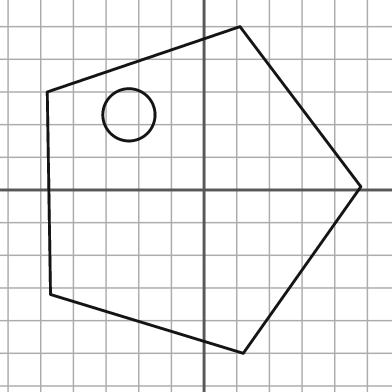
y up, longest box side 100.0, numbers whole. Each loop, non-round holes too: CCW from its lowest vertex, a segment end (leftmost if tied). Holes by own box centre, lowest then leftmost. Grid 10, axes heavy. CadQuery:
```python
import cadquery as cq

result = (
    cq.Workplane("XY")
    .moveTo(12.0, -50.0)
    .lineTo(48.0, 1.0)
    .lineTo(11.0, 50.0)
    .lineTo(-48.0, 30.0)
    .lineTo(-47.0, -32.0)
    .close()
    .moveTo(-23.0, 23.0)
    .circle(8.0)
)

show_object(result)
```